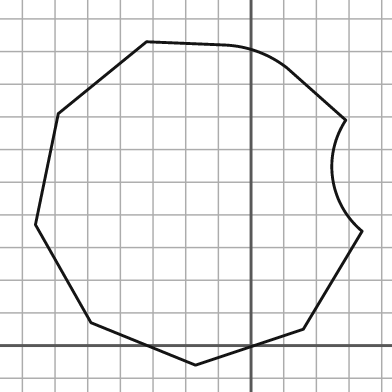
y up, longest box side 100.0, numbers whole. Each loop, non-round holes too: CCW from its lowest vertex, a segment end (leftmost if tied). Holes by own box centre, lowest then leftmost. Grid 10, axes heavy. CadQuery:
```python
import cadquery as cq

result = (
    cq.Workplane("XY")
    .moveTo(-17.0, -6.0)
    .lineTo(16.0, 5.0)
    .lineTo(34.0, 35.0)
    .threePointArc((25.0, 51.0), (29.0, 69.0))
    .lineTo(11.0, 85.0)
    .threePointArc((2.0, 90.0), (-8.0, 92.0))
    .lineTo(-32.0, 93.0)
    .lineTo(-59.0, 71.0)
    .lineTo(-66.0, 37.0)
    .lineTo(-49.0, 7.0)
    .close()
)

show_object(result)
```